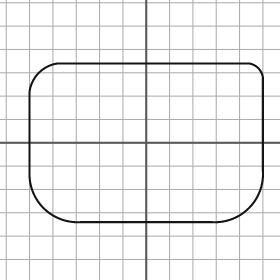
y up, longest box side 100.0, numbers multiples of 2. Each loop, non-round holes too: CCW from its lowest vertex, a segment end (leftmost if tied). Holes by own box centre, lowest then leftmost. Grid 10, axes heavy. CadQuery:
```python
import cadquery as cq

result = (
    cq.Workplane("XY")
    .moveTo(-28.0, -34.0)
    .lineTo(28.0, -34.0)
    .threePointArc((44.0, -28.0), (50.0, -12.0))
    .lineTo(50.0, 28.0)
    .threePointArc((48.0, 32.0), (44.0, 34.0))
    .lineTo(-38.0, 34.0)
    .threePointArc((-46.0, 30.0), (-50.0, 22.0))
    .lineTo(-50.0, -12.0)
    .threePointArc((-44.0, -28.0), (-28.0, -34.0))
    .close()
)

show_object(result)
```